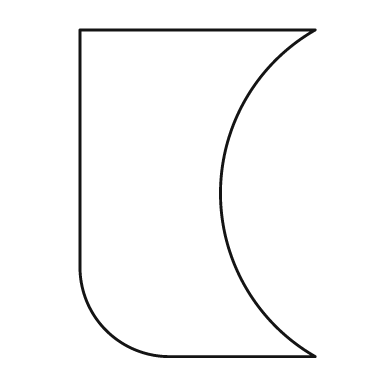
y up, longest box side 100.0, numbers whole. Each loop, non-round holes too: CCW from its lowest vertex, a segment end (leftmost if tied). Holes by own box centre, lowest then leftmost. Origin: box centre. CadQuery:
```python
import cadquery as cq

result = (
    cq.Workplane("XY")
    .moveTo(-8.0, -50.0)
    .lineTo(36.0, -50.0)
    .threePointArc((7.0, 0.0), (36.0, 50.0))
    .lineTo(-36.0, 50.0)
    .lineTo(-36.0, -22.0)
    .threePointArc((-28.0, -42.0), (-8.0, -50.0))
    .close()
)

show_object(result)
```